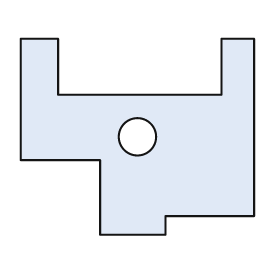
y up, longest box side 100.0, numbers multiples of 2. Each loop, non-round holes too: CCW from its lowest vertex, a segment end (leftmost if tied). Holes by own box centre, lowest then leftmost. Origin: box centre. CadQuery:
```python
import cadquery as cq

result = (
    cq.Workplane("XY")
    .moveTo(-16.0, -42.0)
    .lineTo(12.0, -42.0)
    .lineTo(12.0, -34.0)
    .lineTo(50.0, -34.0)
    .lineTo(50.0, 42.0)
    .lineTo(36.0, 42.0)
    .lineTo(36.0, 18.0)
    .lineTo(-34.0, 18.0)
    .lineTo(-34.0, 42.0)
    .lineTo(-50.0, 42.0)
    .lineTo(-50.0, -10.0)
    .lineTo(-16.0, -10.0)
    .close()
    .moveTo(0.0, 0.0)
    .circle(8.0)
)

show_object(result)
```